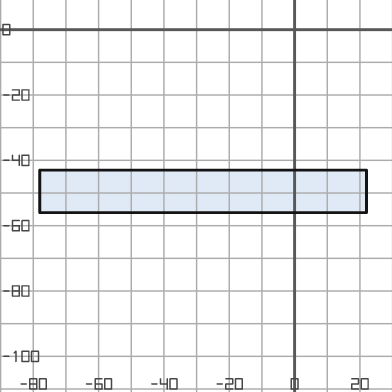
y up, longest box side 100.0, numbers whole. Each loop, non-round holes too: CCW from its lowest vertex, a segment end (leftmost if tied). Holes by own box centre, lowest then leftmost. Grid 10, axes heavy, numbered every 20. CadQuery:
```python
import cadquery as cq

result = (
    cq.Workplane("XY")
    .moveTo(-78.0, -56.0)
    .lineTo(22.0, -56.0)
    .lineTo(22.0, -43.0)
    .lineTo(-78.0, -43.0)
    .close()
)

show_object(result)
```